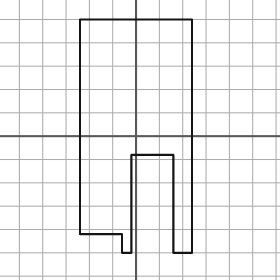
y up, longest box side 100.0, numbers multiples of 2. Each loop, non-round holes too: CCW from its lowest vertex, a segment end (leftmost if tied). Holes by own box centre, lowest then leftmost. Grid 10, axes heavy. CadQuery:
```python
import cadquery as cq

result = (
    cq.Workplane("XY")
    .moveTo(-6.0, -50.0)
    .lineTo(-2.0, -50.0)
    .lineTo(-2.0, -8.0)
    .lineTo(16.0, -8.0)
    .lineTo(16.0, -50.0)
    .lineTo(24.0, -50.0)
    .lineTo(24.0, 50.0)
    .lineTo(-24.0, 50.0)
    .lineTo(-24.0, -42.0)
    .lineTo(-6.0, -42.0)
    .close()
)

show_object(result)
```